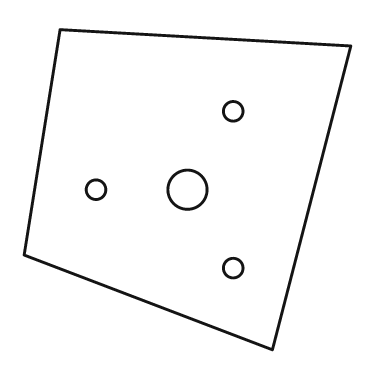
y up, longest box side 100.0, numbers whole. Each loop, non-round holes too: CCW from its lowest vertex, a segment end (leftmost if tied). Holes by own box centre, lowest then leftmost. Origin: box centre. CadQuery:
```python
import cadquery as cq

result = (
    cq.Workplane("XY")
    .moveTo(26.0, -49.0)
    .lineTo(50.0, 44.0)
    .lineTo(-39.0, 49.0)
    .lineTo(-50.0, -20.0)
    .close()
    .moveTo(14.0, -24.0)
    .circle(3.0)
    .moveTo(-28.0, 0.0)
    .circle(3.0)
    .moveTo(0.0, 0.0)
    .circle(6.0)
    .moveTo(14.0, 24.0)
    .circle(3.0)
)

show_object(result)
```